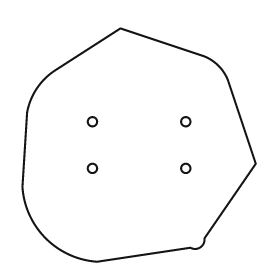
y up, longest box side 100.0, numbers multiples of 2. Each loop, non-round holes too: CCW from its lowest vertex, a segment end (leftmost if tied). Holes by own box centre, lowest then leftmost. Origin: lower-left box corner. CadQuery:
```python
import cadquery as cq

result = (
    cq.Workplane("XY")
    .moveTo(32.0, 0.0)
    .lineTo(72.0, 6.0)
    .threePointArc((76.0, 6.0), (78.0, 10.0))
    .lineTo(100.0, 42.0)
    .lineTo(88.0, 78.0)
    .threePointArc((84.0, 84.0), (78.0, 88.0))
    .lineTo(42.0, 100.0)
    .lineTo(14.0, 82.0)
    .threePointArc((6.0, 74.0), (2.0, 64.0))
    .lineTo(0.0, 32.0)
    .threePointArc((10.0, 10.0), (32.0, 0.0))
    .close()
    .moveTo(30.0, 40.0)
    .circle(2.0)
    .moveTo(70.0, 40.0)
    .circle(2.0)
    .moveTo(30.0, 60.0)
    .circle(2.0)
    .moveTo(70.0, 60.0)
    .circle(2.0)
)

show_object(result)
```